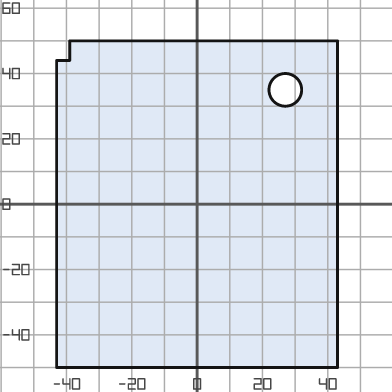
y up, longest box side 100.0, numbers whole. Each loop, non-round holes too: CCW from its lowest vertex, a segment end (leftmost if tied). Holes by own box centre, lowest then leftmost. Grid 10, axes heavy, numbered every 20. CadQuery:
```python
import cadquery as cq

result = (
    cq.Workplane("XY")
    .moveTo(-43.0, -50.0)
    .lineTo(43.0, -50.0)
    .lineTo(43.0, 50.0)
    .lineTo(-39.0, 50.0)
    .lineTo(-39.0, 44.0)
    .lineTo(-43.0, 44.0)
    .close()
    .moveTo(27.0, 35.0)
    .circle(5.0)
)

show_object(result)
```